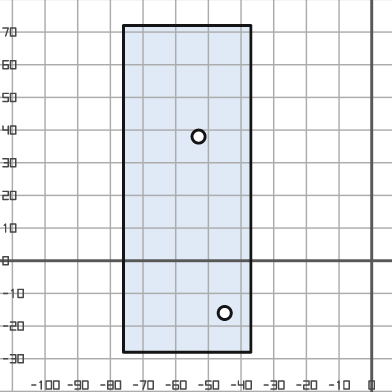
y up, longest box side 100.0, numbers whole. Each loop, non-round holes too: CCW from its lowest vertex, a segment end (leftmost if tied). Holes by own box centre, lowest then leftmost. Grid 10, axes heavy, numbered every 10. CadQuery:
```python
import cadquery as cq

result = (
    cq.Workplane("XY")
    .moveTo(-76.0, -28.0)
    .lineTo(-37.0, -28.0)
    .lineTo(-37.0, 72.0)
    .lineTo(-76.0, 72.0)
    .close()
    .moveTo(-45.0, -16.0)
    .circle(2.0)
    .moveTo(-53.0, 38.0)
    .circle(2.0)
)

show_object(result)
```